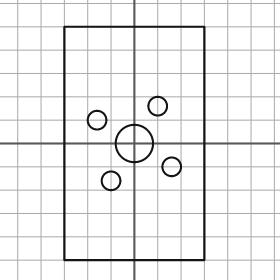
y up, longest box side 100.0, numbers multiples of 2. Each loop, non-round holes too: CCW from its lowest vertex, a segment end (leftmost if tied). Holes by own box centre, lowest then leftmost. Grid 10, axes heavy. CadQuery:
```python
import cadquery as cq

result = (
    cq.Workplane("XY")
    .moveTo(-30.0, -50.0)
    .lineTo(30.0, -50.0)
    .lineTo(30.0, 50.0)
    .lineTo(-30.0, 50.0)
    .close()
    .moveTo(-10.0, -16.0)
    .circle(4.0)
    .moveTo(16.0, -10.0)
    .circle(4.0)
    .moveTo(0.0, 0.0)
    .circle(8.0)
    .moveTo(-16.0, 10.0)
    .circle(4.0)
    .moveTo(10.0, 16.0)
    .circle(4.0)
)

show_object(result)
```